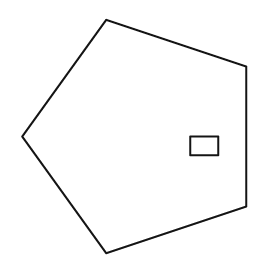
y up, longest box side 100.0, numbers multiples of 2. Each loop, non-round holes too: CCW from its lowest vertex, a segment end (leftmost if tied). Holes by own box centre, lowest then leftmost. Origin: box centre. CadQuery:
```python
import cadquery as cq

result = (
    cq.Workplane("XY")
    .moveTo(-12.0, -50.0)
    .lineTo(48.0, -30.0)
    .lineTo(48.0, 30.0)
    .lineTo(-12.0, 50.0)
    .lineTo(-48.0, 0.0)
    .close()
    .moveTo(24.0, -8.0)
    .lineTo(36.0, -8.0)
    .lineTo(36.0, 0.0)
    .lineTo(24.0, 0.0)
    .close()
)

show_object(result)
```